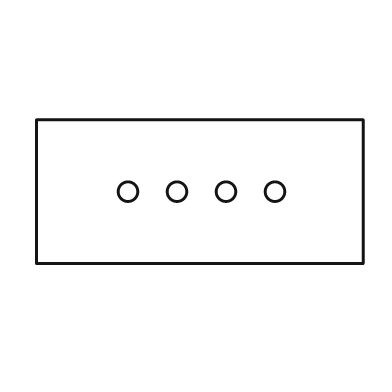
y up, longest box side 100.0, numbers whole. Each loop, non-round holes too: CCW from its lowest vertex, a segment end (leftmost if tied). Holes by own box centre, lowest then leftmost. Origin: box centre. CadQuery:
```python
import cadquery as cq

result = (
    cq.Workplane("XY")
    .moveTo(-50.0, -22.0)
    .lineTo(50.0, -22.0)
    .lineTo(50.0, 22.0)
    .lineTo(-50.0, 22.0)
    .close()
    .moveTo(-22.0, 0.0)
    .circle(3.0)
    .moveTo(-7.0, 0.0)
    .circle(3.0)
    .moveTo(8.0, 0.0)
    .circle(3.0)
    .moveTo(23.0, 0.0)
    .circle(3.0)
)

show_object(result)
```